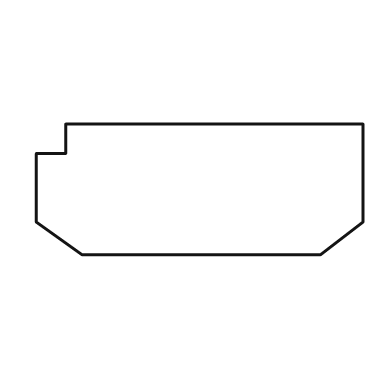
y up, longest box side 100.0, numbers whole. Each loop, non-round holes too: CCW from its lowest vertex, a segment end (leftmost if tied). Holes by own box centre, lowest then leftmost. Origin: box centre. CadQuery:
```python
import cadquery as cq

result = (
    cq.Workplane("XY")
    .moveTo(-36.0, -20.0)
    .lineTo(37.0, -20.0)
    .lineTo(50.0, -10.0)
    .lineTo(50.0, 20.0)
    .lineTo(-41.0, 20.0)
    .lineTo(-41.0, 11.0)
    .lineTo(-50.0, 11.0)
    .lineTo(-50.0, -10.0)
    .close()
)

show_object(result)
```